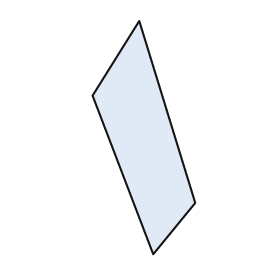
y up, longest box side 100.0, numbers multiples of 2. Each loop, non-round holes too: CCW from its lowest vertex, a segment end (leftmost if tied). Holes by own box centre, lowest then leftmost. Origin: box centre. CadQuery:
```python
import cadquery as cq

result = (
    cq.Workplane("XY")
    .moveTo(4.0, -50.0)
    .lineTo(22.0, -28.0)
    .lineTo(-2.0, 50.0)
    .lineTo(-22.0, 18.0)
    .close()
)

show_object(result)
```